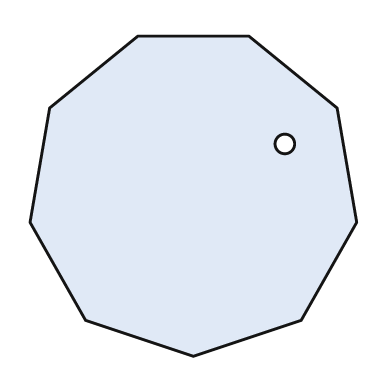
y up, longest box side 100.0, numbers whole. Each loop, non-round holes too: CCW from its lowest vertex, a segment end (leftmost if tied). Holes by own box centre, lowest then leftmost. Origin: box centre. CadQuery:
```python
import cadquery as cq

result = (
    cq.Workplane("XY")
    .moveTo(0.0, -49.0)
    .lineTo(33.0, -38.0)
    .lineTo(50.0, -8.0)
    .lineTo(44.0, 27.0)
    .lineTo(17.0, 49.0)
    .lineTo(-17.0, 49.0)
    .lineTo(-44.0, 27.0)
    .lineTo(-50.0, -8.0)
    .lineTo(-33.0, -38.0)
    .close()
    .moveTo(28.0, 16.0)
    .circle(3.0)
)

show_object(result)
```